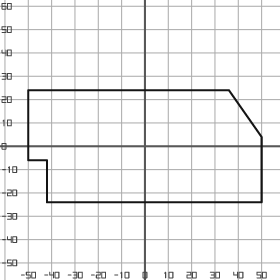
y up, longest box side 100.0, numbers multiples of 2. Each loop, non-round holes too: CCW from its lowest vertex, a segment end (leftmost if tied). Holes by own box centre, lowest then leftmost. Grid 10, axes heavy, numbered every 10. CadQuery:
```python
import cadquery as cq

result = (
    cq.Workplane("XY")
    .moveTo(-42.0, -24.0)
    .lineTo(50.0, -24.0)
    .lineTo(50.0, 4.0)
    .lineTo(36.0, 24.0)
    .lineTo(-50.0, 24.0)
    .lineTo(-50.0, -6.0)
    .lineTo(-42.0, -6.0)
    .close()
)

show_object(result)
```